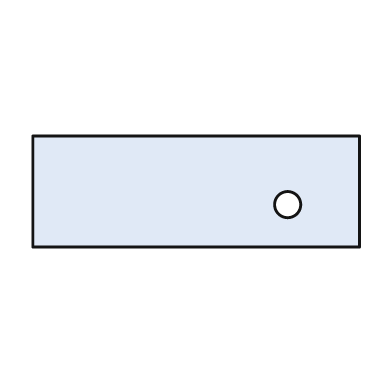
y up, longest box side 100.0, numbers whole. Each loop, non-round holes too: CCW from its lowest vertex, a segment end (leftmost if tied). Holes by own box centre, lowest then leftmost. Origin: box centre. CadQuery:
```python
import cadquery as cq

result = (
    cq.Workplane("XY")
    .moveTo(-50.0, -17.0)
    .lineTo(50.0, -17.0)
    .lineTo(50.0, 17.0)
    .lineTo(-50.0, 17.0)
    .close()
    .moveTo(28.0, -4.0)
    .circle(4.0)
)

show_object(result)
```